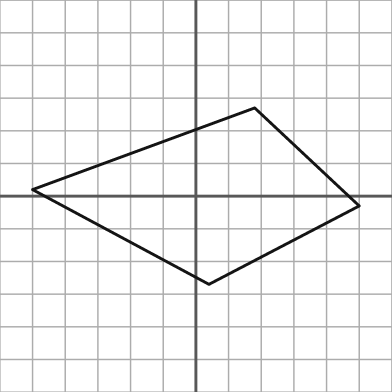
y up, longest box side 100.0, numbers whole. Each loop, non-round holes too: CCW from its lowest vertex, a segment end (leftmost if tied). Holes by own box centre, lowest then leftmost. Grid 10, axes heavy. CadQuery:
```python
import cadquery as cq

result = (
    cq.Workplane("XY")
    .moveTo(4.0, -27.0)
    .lineTo(50.0, -3.0)
    .lineTo(18.0, 27.0)
    .lineTo(-50.0, 2.0)
    .close()
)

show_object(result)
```